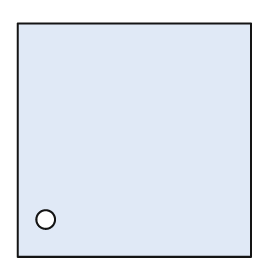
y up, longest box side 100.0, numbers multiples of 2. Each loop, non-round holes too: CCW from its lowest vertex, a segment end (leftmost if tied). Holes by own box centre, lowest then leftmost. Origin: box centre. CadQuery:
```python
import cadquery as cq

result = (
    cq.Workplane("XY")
    .moveTo(-50.0, -50.0)
    .lineTo(50.0, -50.0)
    .lineTo(50.0, 50.0)
    .lineTo(-50.0, 50.0)
    .close()
    .moveTo(-38.0, -34.0)
    .circle(4.0)
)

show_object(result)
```